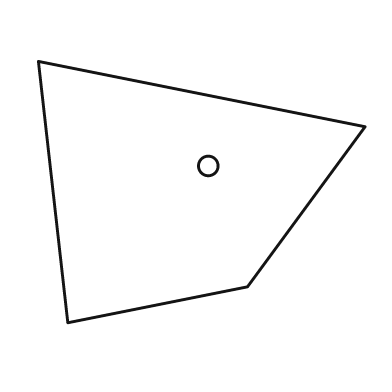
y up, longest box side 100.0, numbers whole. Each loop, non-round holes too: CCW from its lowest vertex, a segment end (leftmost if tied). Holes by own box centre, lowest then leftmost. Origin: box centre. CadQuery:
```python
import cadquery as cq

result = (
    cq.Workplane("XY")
    .moveTo(-41.0, -40.0)
    .lineTo(14.0, -29.0)
    .lineTo(50.0, 20.0)
    .lineTo(-50.0, 40.0)
    .close()
    .moveTo(2.0, 8.0)
    .circle(3.0)
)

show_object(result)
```